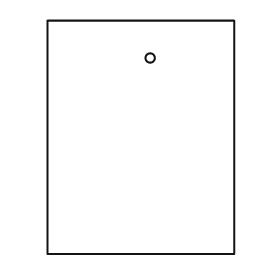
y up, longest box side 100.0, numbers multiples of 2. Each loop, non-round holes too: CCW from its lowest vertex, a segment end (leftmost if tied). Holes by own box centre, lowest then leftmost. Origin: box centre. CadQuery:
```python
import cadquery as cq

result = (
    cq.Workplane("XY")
    .moveTo(-40.0, -50.0)
    .lineTo(40.0, -50.0)
    .lineTo(40.0, 50.0)
    .lineTo(-40.0, 50.0)
    .close()
    .moveTo(4.0, 34.0)
    .circle(2.0)
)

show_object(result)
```